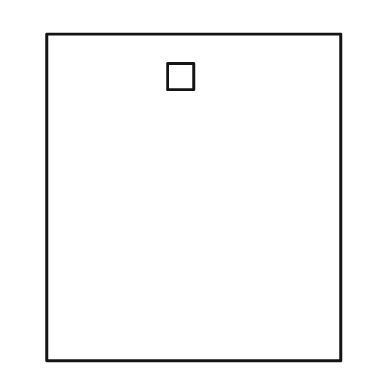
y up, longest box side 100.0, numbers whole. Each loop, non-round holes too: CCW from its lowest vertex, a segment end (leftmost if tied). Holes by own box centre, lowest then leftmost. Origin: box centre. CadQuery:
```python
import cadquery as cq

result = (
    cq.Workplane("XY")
    .moveTo(-45.0, -50.0)
    .lineTo(45.0, -50.0)
    .lineTo(45.0, 50.0)
    .lineTo(-45.0, 50.0)
    .close()
    .moveTo(-8.0, 33.0)
    .lineTo(0.0, 33.0)
    .lineTo(0.0, 41.0)
    .lineTo(-8.0, 41.0)
    .close()
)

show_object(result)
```